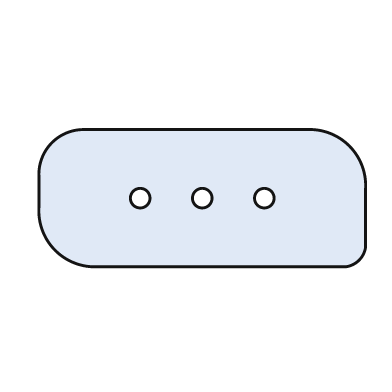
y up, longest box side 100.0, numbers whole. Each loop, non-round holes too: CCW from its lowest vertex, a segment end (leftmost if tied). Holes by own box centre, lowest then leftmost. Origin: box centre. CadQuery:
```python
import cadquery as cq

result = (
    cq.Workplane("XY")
    .moveTo(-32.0, -21.0)
    .lineTo(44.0, -21.0)
    .threePointArc((48.0, -19.0), (50.0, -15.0))
    .lineTo(50.0, 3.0)
    .threePointArc((45.0, 16.0), (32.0, 21.0))
    .lineTo(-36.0, 21.0)
    .threePointArc((-46.0, 17.0), (-50.0, 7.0))
    .lineTo(-50.0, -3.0)
    .threePointArc((-45.0, -16.0), (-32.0, -21.0))
    .close()
    .moveTo(-19.0, 0.0)
    .circle(3.0)
    .moveTo(0.0, 0.0)
    .circle(3.0)
    .moveTo(19.0, 0.0)
    .circle(3.0)
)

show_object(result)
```